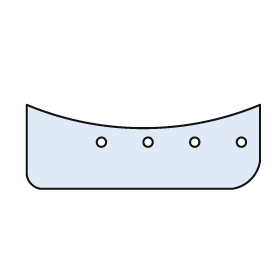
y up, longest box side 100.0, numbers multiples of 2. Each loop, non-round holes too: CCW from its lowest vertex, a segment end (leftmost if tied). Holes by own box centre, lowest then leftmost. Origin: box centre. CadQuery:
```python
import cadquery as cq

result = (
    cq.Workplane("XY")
    .moveTo(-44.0, -18.0)
    .lineTo(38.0, -18.0)
    .threePointArc((46.0, -14.0), (50.0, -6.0))
    .lineTo(50.0, 18.0)
    .threePointArc((0.0, 8.0), (-50.0, 18.0))
    .lineTo(-50.0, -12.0)
    .threePointArc((-48.0, -16.0), (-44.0, -18.0))
    .close()
    .moveTo(-18.0, 2.0)
    .circle(2.0)
    .moveTo(2.0, 2.0)
    .circle(2.0)
    .moveTo(22.0, 2.0)
    .circle(2.0)
    .moveTo(42.0, 2.0)
    .circle(2.0)
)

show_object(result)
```